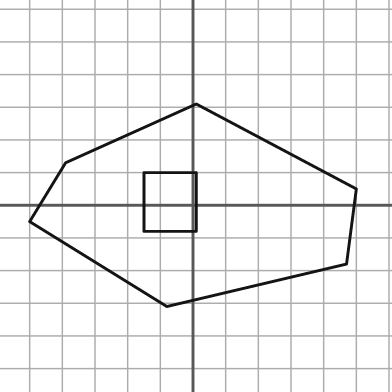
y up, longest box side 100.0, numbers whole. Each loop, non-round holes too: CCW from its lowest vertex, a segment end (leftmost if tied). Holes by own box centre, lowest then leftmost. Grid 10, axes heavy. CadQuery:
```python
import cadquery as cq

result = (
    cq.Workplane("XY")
    .moveTo(-8.0, -31.0)
    .lineTo(47.0, -18.0)
    .lineTo(50.0, 5.0)
    .lineTo(1.0, 31.0)
    .lineTo(-39.0, 13.0)
    .lineTo(-50.0, -5.0)
    .close()
    .moveTo(-15.0, -8.0)
    .lineTo(1.0, -8.0)
    .lineTo(1.0, 10.0)
    .lineTo(-15.0, 10.0)
    .close()
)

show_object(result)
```